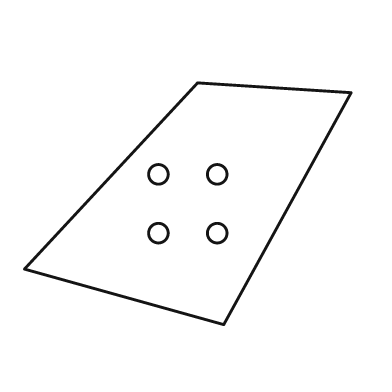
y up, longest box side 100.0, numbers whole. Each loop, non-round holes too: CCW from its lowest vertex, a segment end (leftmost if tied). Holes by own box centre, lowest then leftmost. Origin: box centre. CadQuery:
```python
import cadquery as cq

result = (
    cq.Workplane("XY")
    .moveTo(11.0, -37.0)
    .lineTo(50.0, 34.0)
    .lineTo(3.0, 37.0)
    .lineTo(-50.0, -20.0)
    .close()
    .moveTo(-9.0, -9.0)
    .circle(3.0)
    .moveTo(9.0, -9.0)
    .circle(3.0)
    .moveTo(-9.0, 9.0)
    .circle(3.0)
    .moveTo(9.0, 9.0)
    .circle(3.0)
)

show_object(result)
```